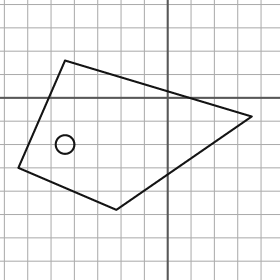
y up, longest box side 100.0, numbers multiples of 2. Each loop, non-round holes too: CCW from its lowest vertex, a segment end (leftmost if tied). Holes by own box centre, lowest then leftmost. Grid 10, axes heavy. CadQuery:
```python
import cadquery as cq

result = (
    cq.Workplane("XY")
    .moveTo(-22.0, -48.0)
    .lineTo(36.0, -8.0)
    .lineTo(-44.0, 16.0)
    .lineTo(-64.0, -30.0)
    .close()
    .moveTo(-44.0, -20.0)
    .circle(4.0)
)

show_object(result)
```